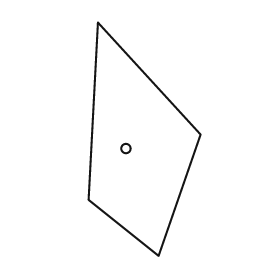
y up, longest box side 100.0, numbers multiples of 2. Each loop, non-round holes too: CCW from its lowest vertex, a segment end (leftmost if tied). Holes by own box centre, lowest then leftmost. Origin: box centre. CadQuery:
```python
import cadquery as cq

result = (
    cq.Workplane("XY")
    .moveTo(6.0, -50.0)
    .lineTo(24.0, 2.0)
    .lineTo(-20.0, 50.0)
    .lineTo(-24.0, -26.0)
    .close()
    .moveTo(-8.0, -4.0)
    .circle(2.0)
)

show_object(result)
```